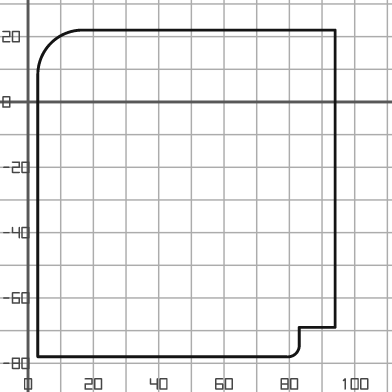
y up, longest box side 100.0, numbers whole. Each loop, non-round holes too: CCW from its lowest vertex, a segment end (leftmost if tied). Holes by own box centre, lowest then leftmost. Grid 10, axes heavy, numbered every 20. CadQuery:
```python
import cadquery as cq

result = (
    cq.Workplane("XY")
    .moveTo(3.0, -78.0)
    .lineTo(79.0, -78.0)
    .threePointArc((82.0, -77.0), (83.0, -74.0))
    .lineTo(83.0, -69.0)
    .lineTo(94.0, -69.0)
    .lineTo(94.0, 22.0)
    .lineTo(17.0, 22.0)
    .threePointArc((7.0, 18.0), (3.0, 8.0))
    .close()
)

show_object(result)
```